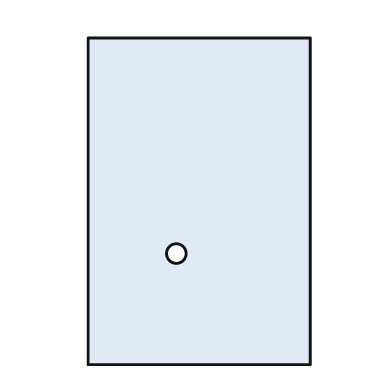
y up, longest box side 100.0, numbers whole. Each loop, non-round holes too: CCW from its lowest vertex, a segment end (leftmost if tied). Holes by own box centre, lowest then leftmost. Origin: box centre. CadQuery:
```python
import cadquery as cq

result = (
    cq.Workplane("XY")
    .moveTo(-34.0, -50.0)
    .lineTo(34.0, -50.0)
    .lineTo(34.0, 50.0)
    .lineTo(-34.0, 50.0)
    .close()
    .moveTo(-7.0, -16.0)
    .circle(3.0)
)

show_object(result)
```